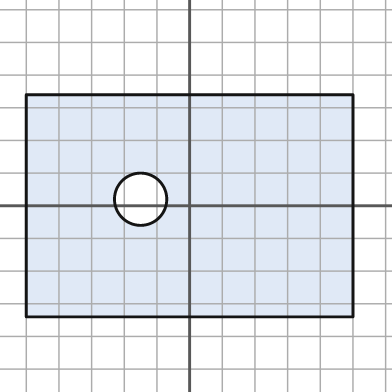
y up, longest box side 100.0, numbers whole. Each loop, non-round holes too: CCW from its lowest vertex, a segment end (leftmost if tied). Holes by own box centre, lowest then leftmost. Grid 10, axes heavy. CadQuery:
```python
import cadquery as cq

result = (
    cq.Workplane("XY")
    .moveTo(-50.0, -34.0)
    .lineTo(50.0, -34.0)
    .lineTo(50.0, 34.0)
    .lineTo(-50.0, 34.0)
    .close()
    .moveTo(-15.0, 2.0)
    .circle(8.0)
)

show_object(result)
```